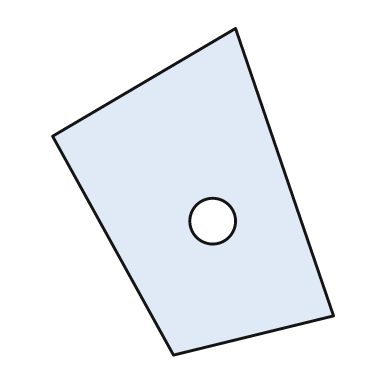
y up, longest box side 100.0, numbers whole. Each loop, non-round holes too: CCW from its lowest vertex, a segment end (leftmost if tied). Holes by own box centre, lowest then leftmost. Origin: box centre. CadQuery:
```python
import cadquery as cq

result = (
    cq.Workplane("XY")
    .moveTo(-6.0, -50.0)
    .lineTo(43.0, -38.0)
    .lineTo(13.0, 50.0)
    .lineTo(-43.0, 17.0)
    .close()
    .moveTo(6.0, -9.0)
    .circle(7.0)
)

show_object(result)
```